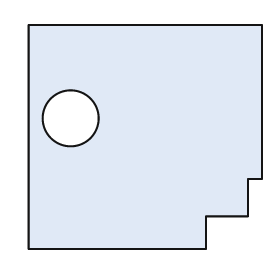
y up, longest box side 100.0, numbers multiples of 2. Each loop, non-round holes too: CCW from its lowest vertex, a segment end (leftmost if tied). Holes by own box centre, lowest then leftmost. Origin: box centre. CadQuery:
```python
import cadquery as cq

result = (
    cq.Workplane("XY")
    .moveTo(-50.0, -48.0)
    .lineTo(26.0, -48.0)
    .lineTo(26.0, -34.0)
    .lineTo(44.0, -34.0)
    .lineTo(44.0, -18.0)
    .lineTo(50.0, -18.0)
    .lineTo(50.0, 48.0)
    .lineTo(-50.0, 48.0)
    .close()
    .moveTo(-32.0, 8.0)
    .circle(12.0)
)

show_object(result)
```